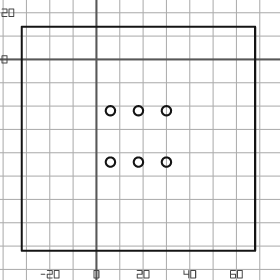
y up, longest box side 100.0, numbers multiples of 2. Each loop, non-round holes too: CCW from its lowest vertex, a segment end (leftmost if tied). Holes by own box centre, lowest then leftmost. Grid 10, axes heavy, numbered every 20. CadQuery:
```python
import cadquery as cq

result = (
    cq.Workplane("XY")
    .moveTo(-32.0, -82.0)
    .lineTo(68.0, -82.0)
    .lineTo(68.0, 14.0)
    .lineTo(-32.0, 14.0)
    .close()
    .moveTo(6.0, -44.0)
    .circle(2.0)
    .moveTo(18.0, -44.0)
    .circle(2.0)
    .moveTo(30.0, -44.0)
    .circle(2.0)
    .moveTo(6.0, -22.0)
    .circle(2.0)
    .moveTo(18.0, -22.0)
    .circle(2.0)
    .moveTo(30.0, -22.0)
    .circle(2.0)
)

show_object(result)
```